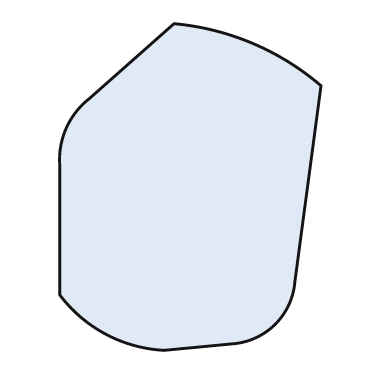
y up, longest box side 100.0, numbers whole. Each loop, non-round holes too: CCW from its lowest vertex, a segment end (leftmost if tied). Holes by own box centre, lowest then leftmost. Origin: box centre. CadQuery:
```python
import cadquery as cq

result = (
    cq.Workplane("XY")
    .moveTo(-8.0, -50.0)
    .lineTo(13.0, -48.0)
    .threePointArc((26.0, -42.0), (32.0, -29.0))
    .lineTo(40.0, 31.0)
    .threePointArc((19.0, 44.0), (-5.0, 50.0))
    .lineTo(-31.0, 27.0)
    .threePointArc((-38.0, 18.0), (-40.0, 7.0))
    .lineTo(-40.0, -33.0)
    .threePointArc((-26.0, -45.0), (-8.0, -50.0))
    .close()
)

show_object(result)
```